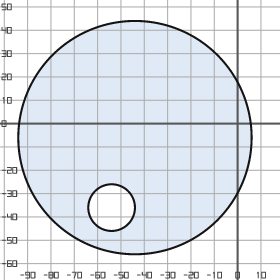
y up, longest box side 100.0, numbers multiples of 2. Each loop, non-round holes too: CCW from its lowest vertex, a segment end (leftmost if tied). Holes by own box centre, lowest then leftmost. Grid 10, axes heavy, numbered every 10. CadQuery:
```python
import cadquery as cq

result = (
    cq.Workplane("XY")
    .moveTo(-44.0, -6.0)
    .circle(50.0)
    .moveTo(-54.0, -36.0)
    .circle(10.0)
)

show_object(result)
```